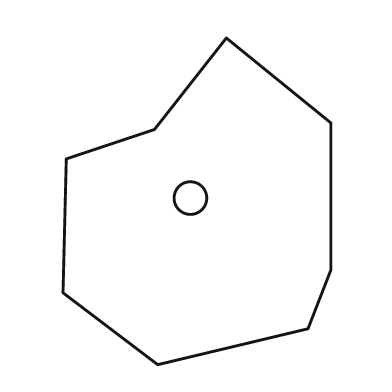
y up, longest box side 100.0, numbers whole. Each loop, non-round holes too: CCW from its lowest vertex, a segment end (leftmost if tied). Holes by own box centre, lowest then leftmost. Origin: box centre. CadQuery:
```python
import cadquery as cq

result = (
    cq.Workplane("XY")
    .moveTo(-12.0, -50.0)
    .lineTo(34.0, -39.0)
    .lineTo(41.0, -21.0)
    .lineTo(41.0, 24.0)
    .lineTo(9.0, 50.0)
    .lineTo(-13.0, 22.0)
    .lineTo(-40.0, 13.0)
    .lineTo(-41.0, -28.0)
    .close()
    .moveTo(-2.0, 1.0)
    .circle(5.0)
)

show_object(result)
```